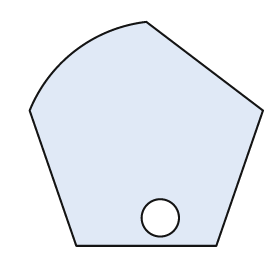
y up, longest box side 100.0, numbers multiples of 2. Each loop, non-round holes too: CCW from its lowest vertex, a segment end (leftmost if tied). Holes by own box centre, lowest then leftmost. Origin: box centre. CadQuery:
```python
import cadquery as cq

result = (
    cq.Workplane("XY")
    .moveTo(-30.0, -48.0)
    .lineTo(30.0, -48.0)
    .lineTo(50.0, 10.0)
    .lineTo(0.0, 48.0)
    .threePointArc((-30.0, 36.0), (-50.0, 10.0))
    .close()
    .moveTo(6.0, -36.0)
    .circle(8.0)
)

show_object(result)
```